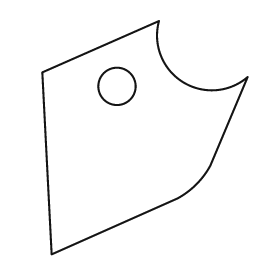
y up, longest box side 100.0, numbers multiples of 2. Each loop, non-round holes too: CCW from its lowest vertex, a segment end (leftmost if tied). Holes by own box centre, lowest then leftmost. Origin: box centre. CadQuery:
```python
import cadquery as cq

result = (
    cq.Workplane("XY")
    .moveTo(-40.0, -50.0)
    .lineTo(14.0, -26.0)
    .threePointArc((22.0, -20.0), (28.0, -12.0))
    .lineTo(44.0, 26.0)
    .threePointArc((16.0, 24.0), (6.0, 50.0))
    .lineTo(-44.0, 28.0)
    .close()
    .moveTo(-12.0, 22.0)
    .circle(8.0)
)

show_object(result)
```